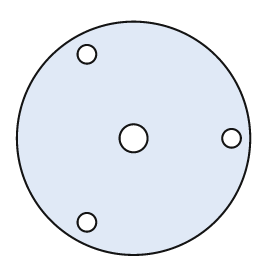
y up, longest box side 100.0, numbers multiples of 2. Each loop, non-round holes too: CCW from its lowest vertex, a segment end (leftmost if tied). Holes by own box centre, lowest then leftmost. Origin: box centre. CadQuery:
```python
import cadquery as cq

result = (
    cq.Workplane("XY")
    .moveTo(0.0, 0.0)
    .circle(50.0)
    .moveTo(-20.0, -36.0)
    .circle(4.0)
    .moveTo(0.0, 0.0)
    .circle(6.0)
    .moveTo(42.0, 0.0)
    .circle(4.0)
    .moveTo(-20.0, 36.0)
    .circle(4.0)
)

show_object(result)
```